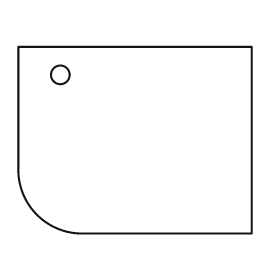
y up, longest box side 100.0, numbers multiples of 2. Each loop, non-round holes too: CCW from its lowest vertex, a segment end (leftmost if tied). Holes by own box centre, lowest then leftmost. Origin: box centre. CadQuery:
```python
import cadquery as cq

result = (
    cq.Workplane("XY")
    .moveTo(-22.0, -40.0)
    .lineTo(50.0, -40.0)
    .lineTo(50.0, 40.0)
    .lineTo(-50.0, 40.0)
    .lineTo(-50.0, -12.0)
    .threePointArc((-42.0, -32.0), (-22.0, -40.0))
    .close()
    .moveTo(-32.0, 28.0)
    .circle(4.0)
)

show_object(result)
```